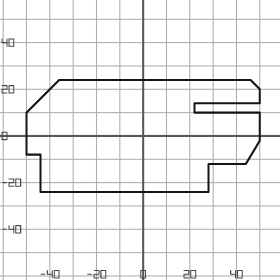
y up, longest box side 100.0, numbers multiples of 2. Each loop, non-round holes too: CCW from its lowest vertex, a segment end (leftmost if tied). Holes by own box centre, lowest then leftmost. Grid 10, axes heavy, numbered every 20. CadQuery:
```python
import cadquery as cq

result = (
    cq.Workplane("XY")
    .moveTo(-44.0, -24.0)
    .lineTo(28.0, -24.0)
    .lineTo(28.0, -12.0)
    .lineTo(44.0, -12.0)
    .lineTo(50.0, -2.0)
    .lineTo(50.0, 10.0)
    .lineTo(22.0, 10.0)
    .lineTo(22.0, 14.0)
    .lineTo(50.0, 14.0)
    .lineTo(50.0, 20.0)
    .lineTo(46.0, 24.0)
    .lineTo(-36.0, 24.0)
    .lineTo(-50.0, 10.0)
    .lineTo(-50.0, -8.0)
    .lineTo(-44.0, -8.0)
    .close()
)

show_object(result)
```